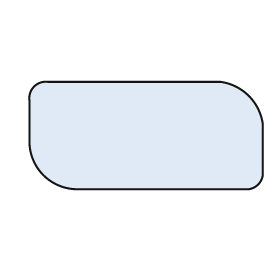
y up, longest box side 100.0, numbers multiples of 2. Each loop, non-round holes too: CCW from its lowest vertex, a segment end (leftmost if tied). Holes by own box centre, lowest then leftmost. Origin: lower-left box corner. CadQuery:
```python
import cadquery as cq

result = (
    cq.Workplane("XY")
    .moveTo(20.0, 0.0)
    .lineTo(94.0, 0.0)
    .threePointArc((98.0, 2.0), (100.0, 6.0))
    .lineTo(100.0, 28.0)
    .threePointArc((94.0, 40.0), (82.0, 46.0))
    .lineTo(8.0, 46.0)
    .threePointArc((2.0, 44.0), (0.0, 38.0))
    .lineTo(0.0, 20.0)
    .threePointArc((6.0, 6.0), (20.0, 0.0))
    .close()
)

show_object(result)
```